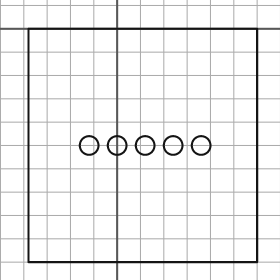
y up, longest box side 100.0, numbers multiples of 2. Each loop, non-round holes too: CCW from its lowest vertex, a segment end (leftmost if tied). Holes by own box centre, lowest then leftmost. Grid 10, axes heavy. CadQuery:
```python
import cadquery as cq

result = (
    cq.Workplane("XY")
    .moveTo(-38.0, -100.0)
    .lineTo(60.0, -100.0)
    .lineTo(60.0, 0.0)
    .lineTo(-38.0, 0.0)
    .close()
    .moveTo(-12.0, -50.0)
    .circle(4.0)
    .moveTo(0.0, -50.0)
    .circle(4.0)
    .moveTo(12.0, -50.0)
    .circle(4.0)
    .moveTo(24.0, -50.0)
    .circle(4.0)
    .moveTo(36.0, -50.0)
    .circle(4.0)
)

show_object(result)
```